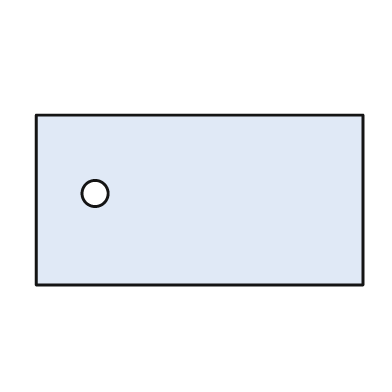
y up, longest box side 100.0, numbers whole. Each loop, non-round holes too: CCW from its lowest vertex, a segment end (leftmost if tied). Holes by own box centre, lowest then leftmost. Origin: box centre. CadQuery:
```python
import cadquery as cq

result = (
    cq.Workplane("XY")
    .moveTo(-50.0, -26.0)
    .lineTo(50.0, -26.0)
    .lineTo(50.0, 26.0)
    .lineTo(-50.0, 26.0)
    .close()
    .moveTo(-32.0, 2.0)
    .circle(4.0)
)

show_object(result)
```